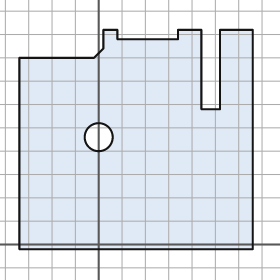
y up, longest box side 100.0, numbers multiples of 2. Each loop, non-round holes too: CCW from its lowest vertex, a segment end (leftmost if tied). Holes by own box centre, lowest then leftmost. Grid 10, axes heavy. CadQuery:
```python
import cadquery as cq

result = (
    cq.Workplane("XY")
    .moveTo(-34.0, -2.0)
    .lineTo(66.0, -2.0)
    .lineTo(66.0, 92.0)
    .lineTo(52.0, 92.0)
    .lineTo(52.0, 58.0)
    .lineTo(44.0, 58.0)
    .lineTo(44.0, 92.0)
    .lineTo(34.0, 92.0)
    .lineTo(34.0, 88.0)
    .lineTo(8.0, 88.0)
    .lineTo(8.0, 92.0)
    .lineTo(2.0, 92.0)
    .lineTo(2.0, 84.0)
    .lineTo(-2.0, 80.0)
    .lineTo(-34.0, 80.0)
    .close()
    .moveTo(0.0, 46.0)
    .circle(6.0)
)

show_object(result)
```